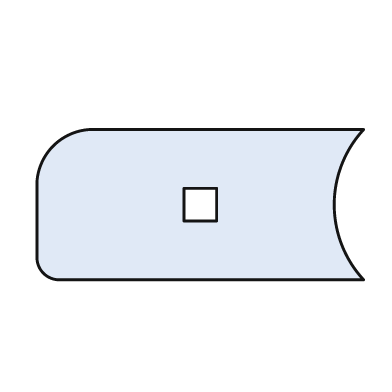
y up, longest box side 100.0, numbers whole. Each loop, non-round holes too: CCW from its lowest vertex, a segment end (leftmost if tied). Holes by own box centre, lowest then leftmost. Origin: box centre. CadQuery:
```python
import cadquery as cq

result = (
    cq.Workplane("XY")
    .moveTo(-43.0, -23.0)
    .lineTo(50.0, -23.0)
    .threePointArc((41.0, 0.0), (50.0, 23.0))
    .lineTo(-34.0, 23.0)
    .threePointArc((-45.0, 18.0), (-50.0, 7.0))
    .lineTo(-50.0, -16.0)
    .threePointArc((-48.0, -21.0), (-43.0, -23.0))
    .close()
    .moveTo(-5.0, -5.0)
    .lineTo(5.0, -5.0)
    .lineTo(5.0, 5.0)
    .lineTo(-5.0, 5.0)
    .close()
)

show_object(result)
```